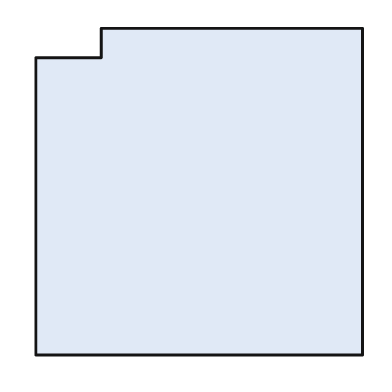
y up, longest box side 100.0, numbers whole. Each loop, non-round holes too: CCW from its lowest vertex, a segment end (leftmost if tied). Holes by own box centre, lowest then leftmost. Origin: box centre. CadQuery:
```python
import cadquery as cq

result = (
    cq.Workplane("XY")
    .moveTo(-50.0, -50.0)
    .lineTo(50.0, -50.0)
    .lineTo(50.0, 50.0)
    .lineTo(-30.0, 50.0)
    .lineTo(-30.0, 41.0)
    .lineTo(-50.0, 41.0)
    .close()
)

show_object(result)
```